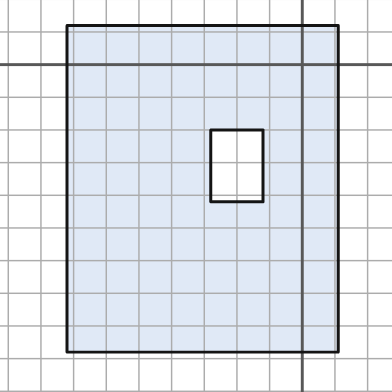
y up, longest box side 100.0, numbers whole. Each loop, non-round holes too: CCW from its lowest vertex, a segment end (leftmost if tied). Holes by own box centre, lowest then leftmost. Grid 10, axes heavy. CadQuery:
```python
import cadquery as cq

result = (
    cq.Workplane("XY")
    .moveTo(-72.0, -88.0)
    .lineTo(11.0, -88.0)
    .lineTo(11.0, 12.0)
    .lineTo(-72.0, 12.0)
    .close()
    .moveTo(-28.0, -42.0)
    .lineTo(-12.0, -42.0)
    .lineTo(-12.0, -20.0)
    .lineTo(-28.0, -20.0)
    .close()
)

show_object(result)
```